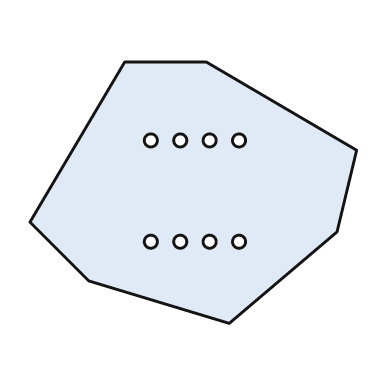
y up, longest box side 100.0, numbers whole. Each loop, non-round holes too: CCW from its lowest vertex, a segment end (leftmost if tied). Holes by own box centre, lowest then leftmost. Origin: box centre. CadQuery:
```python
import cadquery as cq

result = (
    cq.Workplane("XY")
    .moveTo(11.0, -40.0)
    .lineTo(44.0, -12.0)
    .lineTo(50.0, 13.0)
    .lineTo(4.0, 40.0)
    .lineTo(-21.0, 40.0)
    .lineTo(-50.0, -9.0)
    .lineTo(-32.0, -27.0)
    .close()
    .moveTo(-13.0, -15.0)
    .circle(2.0)
    .moveTo(-4.0, -15.0)
    .circle(2.0)
    .moveTo(5.0, -15.0)
    .circle(2.0)
    .moveTo(14.0, -15.0)
    .circle(2.0)
    .moveTo(-13.0, 16.0)
    .circle(2.0)
    .moveTo(-4.0, 16.0)
    .circle(2.0)
    .moveTo(5.0, 16.0)
    .circle(2.0)
    .moveTo(14.0, 16.0)
    .circle(2.0)
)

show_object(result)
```